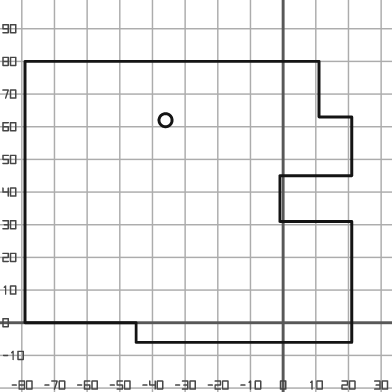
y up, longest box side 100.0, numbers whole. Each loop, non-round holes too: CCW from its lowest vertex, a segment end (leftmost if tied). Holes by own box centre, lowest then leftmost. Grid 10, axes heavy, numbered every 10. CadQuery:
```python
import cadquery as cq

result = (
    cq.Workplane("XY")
    .moveTo(-45.0, -6.0)
    .lineTo(21.0, -6.0)
    .lineTo(21.0, 31.0)
    .lineTo(-1.0, 31.0)
    .lineTo(-1.0, 45.0)
    .lineTo(21.0, 45.0)
    .lineTo(21.0, 63.0)
    .lineTo(11.0, 63.0)
    .lineTo(11.0, 80.0)
    .lineTo(-79.0, 80.0)
    .lineTo(-79.0, 0.0)
    .lineTo(-45.0, 0.0)
    .close()
    .moveTo(-36.0, 62.0)
    .circle(2.0)
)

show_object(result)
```